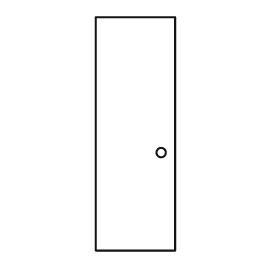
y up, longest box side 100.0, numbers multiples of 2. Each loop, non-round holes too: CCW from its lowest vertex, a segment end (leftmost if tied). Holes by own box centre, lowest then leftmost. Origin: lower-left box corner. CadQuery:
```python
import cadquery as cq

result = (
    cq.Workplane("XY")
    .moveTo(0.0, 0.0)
    .lineTo(34.0, 0.0)
    .lineTo(34.0, 100.0)
    .lineTo(0.0, 100.0)
    .close()
    .moveTo(28.0, 42.0)
    .circle(2.0)
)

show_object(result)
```